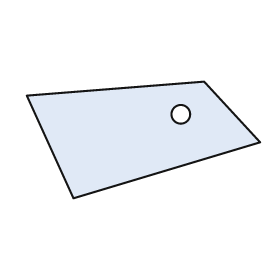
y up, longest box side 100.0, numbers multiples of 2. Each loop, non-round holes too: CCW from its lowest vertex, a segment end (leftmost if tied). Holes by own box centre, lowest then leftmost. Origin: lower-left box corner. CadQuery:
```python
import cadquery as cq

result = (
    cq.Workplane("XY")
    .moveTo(20.0, 0.0)
    .lineTo(100.0, 24.0)
    .lineTo(76.0, 50.0)
    .lineTo(0.0, 44.0)
    .close()
    .moveTo(66.0, 36.0)
    .circle(4.0)
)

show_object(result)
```